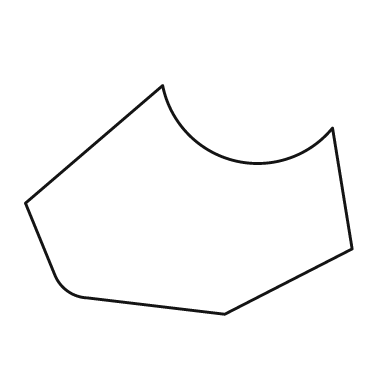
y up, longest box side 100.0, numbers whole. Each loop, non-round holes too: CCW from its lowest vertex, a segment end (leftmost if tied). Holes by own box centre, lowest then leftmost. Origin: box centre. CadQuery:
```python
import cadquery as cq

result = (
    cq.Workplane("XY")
    .moveTo(11.0, -35.0)
    .lineTo(50.0, -15.0)
    .lineTo(44.0, 22.0)
    .threePointArc((14.0, 12.0), (-8.0, 35.0))
    .lineTo(-50.0, -1.0)
    .lineTo(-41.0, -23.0)
    .threePointArc((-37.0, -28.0), (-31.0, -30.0))
    .close()
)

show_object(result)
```